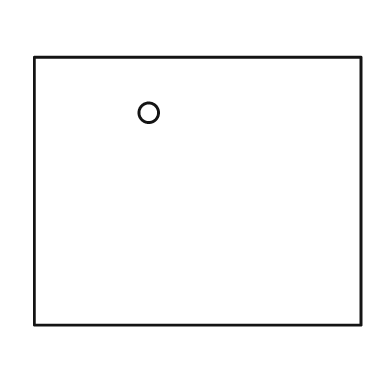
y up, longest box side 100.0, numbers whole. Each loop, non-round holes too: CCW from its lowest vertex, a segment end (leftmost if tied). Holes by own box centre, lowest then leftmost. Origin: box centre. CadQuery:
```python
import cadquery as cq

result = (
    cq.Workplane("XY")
    .moveTo(-50.0, -41.0)
    .lineTo(50.0, -41.0)
    .lineTo(50.0, 41.0)
    .lineTo(-50.0, 41.0)
    .close()
    .moveTo(-15.0, 24.0)
    .circle(3.0)
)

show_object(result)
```